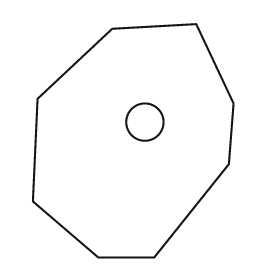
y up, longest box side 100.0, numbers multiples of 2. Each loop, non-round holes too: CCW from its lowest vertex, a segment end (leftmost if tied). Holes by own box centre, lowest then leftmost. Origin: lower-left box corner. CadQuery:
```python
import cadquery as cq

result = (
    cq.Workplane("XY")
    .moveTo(28.0, 0.0)
    .lineTo(52.0, 0.0)
    .lineTo(84.0, 40.0)
    .lineTo(86.0, 66.0)
    .lineTo(70.0, 100.0)
    .lineTo(34.0, 98.0)
    .lineTo(2.0, 68.0)
    .lineTo(0.0, 24.0)
    .close()
    .moveTo(48.0, 58.0)
    .circle(8.0)
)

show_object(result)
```